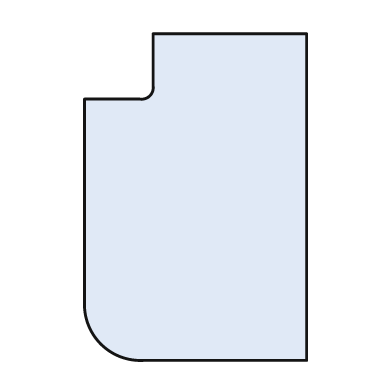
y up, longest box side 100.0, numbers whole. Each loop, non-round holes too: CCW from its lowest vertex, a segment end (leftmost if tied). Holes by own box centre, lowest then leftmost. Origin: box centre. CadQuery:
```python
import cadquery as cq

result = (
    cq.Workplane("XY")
    .moveTo(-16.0, -50.0)
    .lineTo(34.0, -50.0)
    .lineTo(34.0, 50.0)
    .lineTo(-13.0, 50.0)
    .lineTo(-13.0, 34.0)
    .threePointArc((-14.0, 31.0), (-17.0, 30.0))
    .lineTo(-34.0, 30.0)
    .lineTo(-34.0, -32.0)
    .threePointArc((-29.0, -45.0), (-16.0, -50.0))
    .close()
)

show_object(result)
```